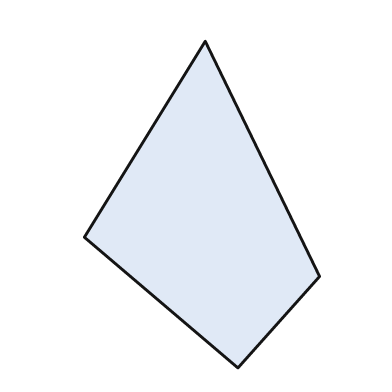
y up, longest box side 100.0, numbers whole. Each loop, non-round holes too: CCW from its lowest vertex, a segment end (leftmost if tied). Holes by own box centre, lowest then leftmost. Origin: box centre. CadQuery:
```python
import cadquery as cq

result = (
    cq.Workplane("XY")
    .moveTo(11.0, -50.0)
    .lineTo(36.0, -22.0)
    .lineTo(1.0, 50.0)
    .lineTo(-36.0, -10.0)
    .close()
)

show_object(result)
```